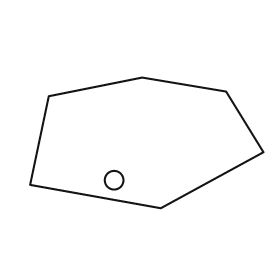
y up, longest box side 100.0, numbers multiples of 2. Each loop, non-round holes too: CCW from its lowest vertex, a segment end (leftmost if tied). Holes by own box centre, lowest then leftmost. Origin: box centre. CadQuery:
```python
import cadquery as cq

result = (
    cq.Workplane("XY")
    .moveTo(6.0, -28.0)
    .lineTo(50.0, -4.0)
    .lineTo(34.0, 22.0)
    .lineTo(-2.0, 28.0)
    .lineTo(-42.0, 20.0)
    .lineTo(-50.0, -18.0)
    .close()
    .moveTo(-14.0, -16.0)
    .circle(4.0)
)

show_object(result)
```